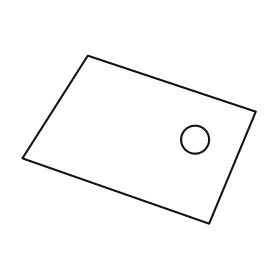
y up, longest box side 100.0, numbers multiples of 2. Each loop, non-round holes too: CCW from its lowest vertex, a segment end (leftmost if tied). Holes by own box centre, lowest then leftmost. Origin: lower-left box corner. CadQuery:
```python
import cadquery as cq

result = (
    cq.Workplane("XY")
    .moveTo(80.0, 0.0)
    .lineTo(100.0, 48.0)
    .lineTo(28.0, 72.0)
    .lineTo(0.0, 28.0)
    .close()
    .moveTo(74.0, 36.0)
    .circle(6.0)
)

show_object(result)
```